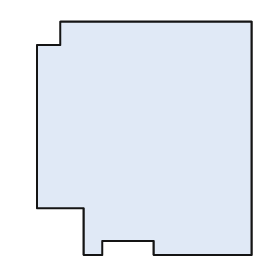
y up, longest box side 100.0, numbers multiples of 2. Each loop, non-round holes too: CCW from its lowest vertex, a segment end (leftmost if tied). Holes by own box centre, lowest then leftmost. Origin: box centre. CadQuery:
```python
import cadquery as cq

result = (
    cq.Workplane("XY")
    .moveTo(-26.0, -50.0)
    .lineTo(-18.0, -50.0)
    .lineTo(-18.0, -44.0)
    .lineTo(4.0, -44.0)
    .lineTo(4.0, -50.0)
    .lineTo(46.0, -50.0)
    .lineTo(46.0, 50.0)
    .lineTo(-36.0, 50.0)
    .lineTo(-36.0, 40.0)
    .lineTo(-46.0, 40.0)
    .lineTo(-46.0, -30.0)
    .lineTo(-26.0, -30.0)
    .close()
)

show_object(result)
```